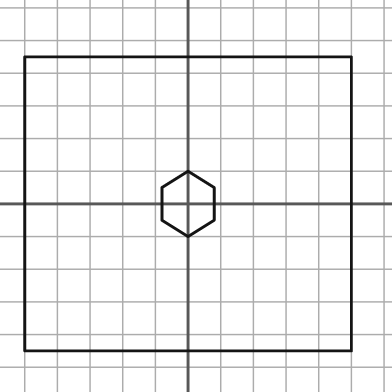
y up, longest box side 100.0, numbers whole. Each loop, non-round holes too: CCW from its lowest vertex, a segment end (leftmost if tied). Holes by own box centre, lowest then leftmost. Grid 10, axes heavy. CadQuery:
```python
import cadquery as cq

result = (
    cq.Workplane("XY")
    .moveTo(-50.0, -45.0)
    .lineTo(50.0, -45.0)
    .lineTo(50.0, 45.0)
    .lineTo(-50.0, 45.0)
    .close()
    .moveTo(0.0, -10.0)
    .lineTo(8.0, -5.0)
    .lineTo(8.0, 5.0)
    .lineTo(0.0, 10.0)
    .lineTo(-8.0, 5.0)
    .lineTo(-8.0, -5.0)
    .close()
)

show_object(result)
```